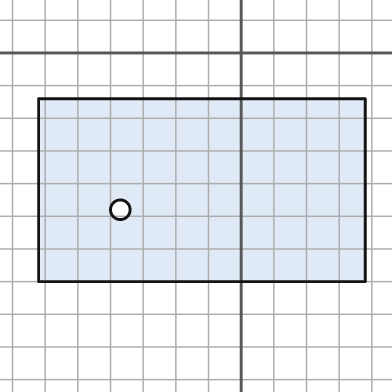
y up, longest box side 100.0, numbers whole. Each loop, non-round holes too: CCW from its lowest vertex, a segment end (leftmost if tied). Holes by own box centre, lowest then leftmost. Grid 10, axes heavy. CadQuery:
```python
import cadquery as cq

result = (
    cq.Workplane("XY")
    .moveTo(-62.0, -70.0)
    .lineTo(38.0, -70.0)
    .lineTo(38.0, -14.0)
    .lineTo(-62.0, -14.0)
    .close()
    .moveTo(-37.0, -48.0)
    .circle(3.0)
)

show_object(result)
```